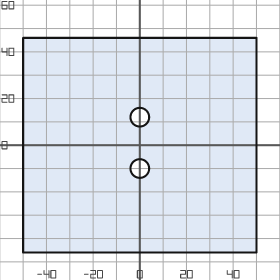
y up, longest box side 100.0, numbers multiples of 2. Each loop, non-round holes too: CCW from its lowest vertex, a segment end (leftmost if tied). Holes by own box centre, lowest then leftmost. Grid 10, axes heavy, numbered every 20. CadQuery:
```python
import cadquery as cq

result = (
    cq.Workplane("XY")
    .moveTo(-50.0, -46.0)
    .lineTo(50.0, -46.0)
    .lineTo(50.0, 46.0)
    .lineTo(-50.0, 46.0)
    .close()
    .moveTo(0.0, -10.0)
    .circle(4.0)
    .moveTo(0.0, 12.0)
    .circle(4.0)
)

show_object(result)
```